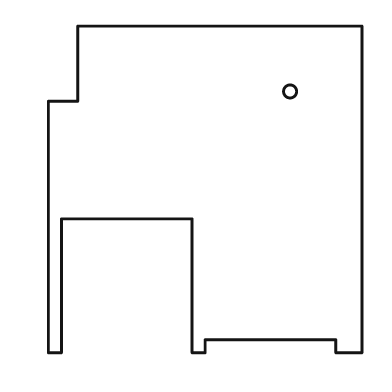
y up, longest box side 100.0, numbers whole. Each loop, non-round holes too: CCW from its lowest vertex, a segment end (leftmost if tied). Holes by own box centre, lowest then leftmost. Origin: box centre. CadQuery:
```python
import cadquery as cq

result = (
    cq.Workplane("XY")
    .moveTo(-48.0, -50.0)
    .lineTo(-44.0, -50.0)
    .lineTo(-44.0, -9.0)
    .lineTo(-4.0, -9.0)
    .lineTo(-4.0, -50.0)
    .lineTo(0.0, -50.0)
    .lineTo(0.0, -46.0)
    .lineTo(40.0, -46.0)
    .lineTo(40.0, -50.0)
    .lineTo(48.0, -50.0)
    .lineTo(48.0, 50.0)
    .lineTo(-39.0, 50.0)
    .lineTo(-39.0, 27.0)
    .lineTo(-48.0, 27.0)
    .close()
    .moveTo(26.0, 30.0)
    .circle(2.0)
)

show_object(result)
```